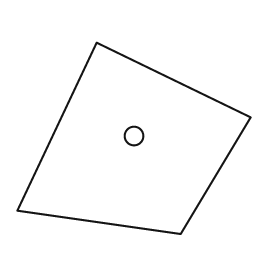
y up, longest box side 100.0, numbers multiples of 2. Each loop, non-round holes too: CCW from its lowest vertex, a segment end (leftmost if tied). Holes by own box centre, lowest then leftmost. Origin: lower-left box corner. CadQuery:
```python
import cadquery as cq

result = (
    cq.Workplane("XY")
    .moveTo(70.0, 0.0)
    .lineTo(100.0, 50.0)
    .lineTo(34.0, 82.0)
    .lineTo(0.0, 10.0)
    .close()
    .moveTo(50.0, 42.0)
    .circle(4.0)
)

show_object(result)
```